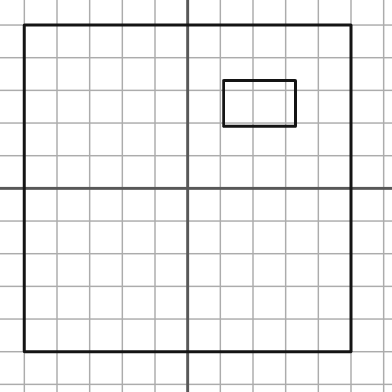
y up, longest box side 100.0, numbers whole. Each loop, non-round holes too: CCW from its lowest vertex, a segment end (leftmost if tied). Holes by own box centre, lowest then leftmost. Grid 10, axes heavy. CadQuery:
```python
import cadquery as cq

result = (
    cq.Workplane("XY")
    .moveTo(-50.0, -50.0)
    .lineTo(50.0, -50.0)
    .lineTo(50.0, 50.0)
    .lineTo(-50.0, 50.0)
    .close()
    .moveTo(11.0, 19.0)
    .lineTo(33.0, 19.0)
    .lineTo(33.0, 33.0)
    .lineTo(11.0, 33.0)
    .close()
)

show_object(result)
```